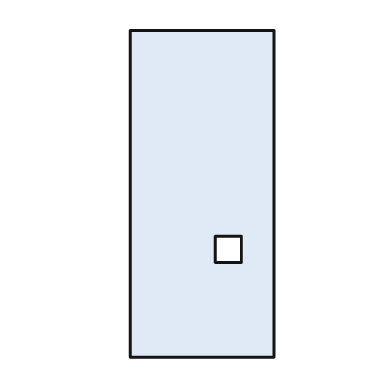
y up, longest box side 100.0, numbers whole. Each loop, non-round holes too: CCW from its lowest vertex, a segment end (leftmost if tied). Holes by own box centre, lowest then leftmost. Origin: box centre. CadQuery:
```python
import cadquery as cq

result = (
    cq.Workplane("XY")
    .moveTo(-22.0, -50.0)
    .lineTo(22.0, -50.0)
    .lineTo(22.0, 50.0)
    .lineTo(-22.0, 50.0)
    .close()
    .moveTo(4.0, -21.0)
    .lineTo(12.0, -21.0)
    .lineTo(12.0, -13.0)
    .lineTo(4.0, -13.0)
    .close()
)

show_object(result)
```